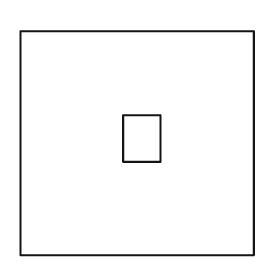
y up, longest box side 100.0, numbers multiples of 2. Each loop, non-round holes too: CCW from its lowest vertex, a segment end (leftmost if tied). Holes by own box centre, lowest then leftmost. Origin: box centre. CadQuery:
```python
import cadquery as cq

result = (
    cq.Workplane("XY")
    .moveTo(-50.0, -48.0)
    .lineTo(50.0, -48.0)
    .lineTo(50.0, 48.0)
    .lineTo(-50.0, 48.0)
    .close()
    .moveTo(-6.0, -8.0)
    .lineTo(10.0, -8.0)
    .lineTo(10.0, 12.0)
    .lineTo(-6.0, 12.0)
    .close()
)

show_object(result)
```